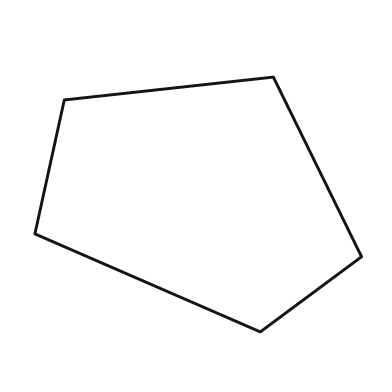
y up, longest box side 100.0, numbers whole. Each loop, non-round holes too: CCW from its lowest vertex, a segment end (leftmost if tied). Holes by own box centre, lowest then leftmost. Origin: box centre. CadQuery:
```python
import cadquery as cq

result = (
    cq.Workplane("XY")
    .moveTo(19.0, -39.0)
    .lineTo(50.0, -16.0)
    .lineTo(23.0, 39.0)
    .lineTo(-41.0, 32.0)
    .lineTo(-50.0, -9.0)
    .close()
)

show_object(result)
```